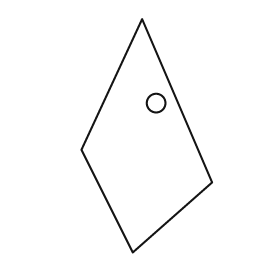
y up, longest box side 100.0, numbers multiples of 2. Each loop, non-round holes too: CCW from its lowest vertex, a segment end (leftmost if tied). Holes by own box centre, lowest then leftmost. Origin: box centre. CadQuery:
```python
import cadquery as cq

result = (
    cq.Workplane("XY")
    .moveTo(-6.0, -50.0)
    .lineTo(28.0, -20.0)
    .lineTo(-2.0, 50.0)
    .lineTo(-28.0, -6.0)
    .close()
    .moveTo(4.0, 14.0)
    .circle(4.0)
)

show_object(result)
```